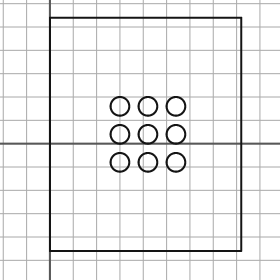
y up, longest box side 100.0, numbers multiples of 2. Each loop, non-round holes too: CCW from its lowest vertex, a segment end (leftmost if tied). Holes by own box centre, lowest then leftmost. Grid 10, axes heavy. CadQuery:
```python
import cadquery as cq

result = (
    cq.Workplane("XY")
    .moveTo(0.0, -46.0)
    .lineTo(82.0, -46.0)
    .lineTo(82.0, 54.0)
    .lineTo(0.0, 54.0)
    .close()
    .moveTo(30.0, -8.0)
    .circle(4.0)
    .moveTo(42.0, -8.0)
    .circle(4.0)
    .moveTo(54.0, -8.0)
    .circle(4.0)
    .moveTo(30.0, 4.0)
    .circle(4.0)
    .moveTo(42.0, 4.0)
    .circle(4.0)
    .moveTo(54.0, 4.0)
    .circle(4.0)
    .moveTo(30.0, 16.0)
    .circle(4.0)
    .moveTo(42.0, 16.0)
    .circle(4.0)
    .moveTo(54.0, 16.0)
    .circle(4.0)
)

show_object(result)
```